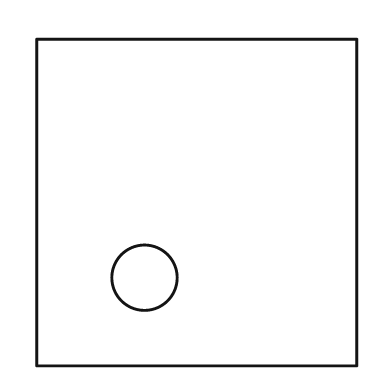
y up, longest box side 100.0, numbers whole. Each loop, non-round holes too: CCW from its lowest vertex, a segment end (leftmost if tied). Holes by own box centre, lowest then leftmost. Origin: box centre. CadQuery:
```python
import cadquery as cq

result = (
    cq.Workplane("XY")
    .moveTo(-49.0, -50.0)
    .lineTo(49.0, -50.0)
    .lineTo(49.0, 50.0)
    .lineTo(-49.0, 50.0)
    .close()
    .moveTo(-16.0, -23.0)
    .circle(10.0)
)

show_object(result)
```